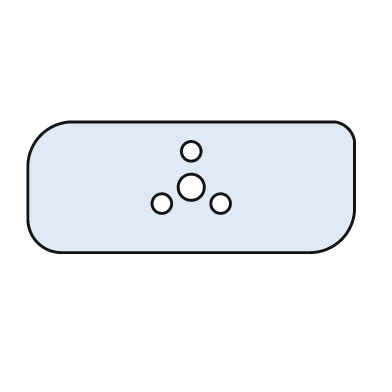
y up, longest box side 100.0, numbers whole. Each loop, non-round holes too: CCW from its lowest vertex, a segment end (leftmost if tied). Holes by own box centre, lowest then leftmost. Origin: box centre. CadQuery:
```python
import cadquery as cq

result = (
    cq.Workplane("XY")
    .moveTo(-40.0, -20.0)
    .lineTo(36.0, -20.0)
    .threePointArc((46.0, -16.0), (50.0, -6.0))
    .lineTo(50.0, 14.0)
    .threePointArc((48.0, 18.0), (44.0, 20.0))
    .lineTo(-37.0, 20.0)
    .threePointArc((-46.0, 16.0), (-50.0, 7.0))
    .lineTo(-50.0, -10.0)
    .threePointArc((-47.0, -17.0), (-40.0, -20.0))
    .close()
    .moveTo(-9.0, -5.0)
    .circle(3.0)
    .moveTo(9.0, -5.0)
    .circle(3.0)
    .moveTo(0.0, 0.0)
    .circle(4.0)
    .moveTo(0.0, 11.0)
    .circle(3.0)
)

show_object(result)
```